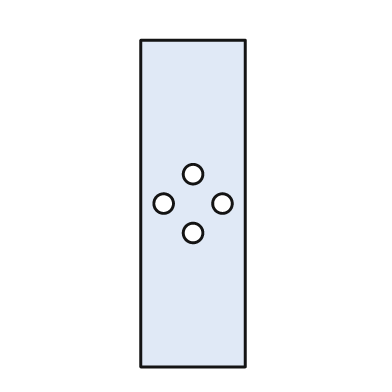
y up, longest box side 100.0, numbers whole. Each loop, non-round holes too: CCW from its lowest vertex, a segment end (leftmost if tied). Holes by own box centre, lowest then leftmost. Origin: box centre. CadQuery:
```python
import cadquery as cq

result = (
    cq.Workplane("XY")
    .moveTo(-16.0, -50.0)
    .lineTo(16.0, -50.0)
    .lineTo(16.0, 50.0)
    .lineTo(-16.0, 50.0)
    .close()
    .moveTo(0.0, -9.0)
    .circle(3.0)
    .moveTo(-9.0, 0.0)
    .circle(3.0)
    .moveTo(9.0, 0.0)
    .circle(3.0)
    .moveTo(0.0, 9.0)
    .circle(3.0)
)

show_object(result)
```